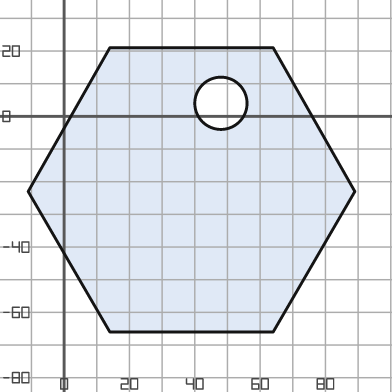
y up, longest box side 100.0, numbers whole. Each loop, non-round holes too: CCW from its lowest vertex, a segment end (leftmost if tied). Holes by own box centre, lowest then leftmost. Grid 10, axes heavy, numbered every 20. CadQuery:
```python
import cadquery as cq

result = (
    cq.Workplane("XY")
    .moveTo(14.0, -66.0)
    .lineTo(64.0, -66.0)
    .lineTo(89.0, -23.0)
    .lineTo(64.0, 21.0)
    .lineTo(14.0, 21.0)
    .lineTo(-11.0, -23.0)
    .close()
    .moveTo(48.0, 4.0)
    .circle(8.0)
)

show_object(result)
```